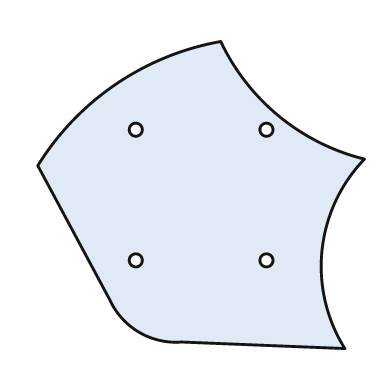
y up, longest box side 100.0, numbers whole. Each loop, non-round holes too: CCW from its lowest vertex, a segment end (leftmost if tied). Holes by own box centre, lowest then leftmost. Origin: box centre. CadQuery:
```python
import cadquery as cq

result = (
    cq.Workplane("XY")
    .moveTo(44.0, -47.0)
    .threePointArc((37.0, -17.0), (50.0, 11.0))
    .threePointArc((24.0, 24.0), (6.0, 47.0))
    .threePointArc((-26.0, 34.0), (-50.0, 9.0))
    .lineTo(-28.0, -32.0)
    .threePointArc((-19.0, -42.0), (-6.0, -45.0))
    .close()
    .moveTo(-20.0, -20.0)
    .circle(2.0)
    .moveTo(20.0, -20.0)
    .circle(2.0)
    .moveTo(-20.0, 20.0)
    .circle(2.0)
    .moveTo(20.0, 20.0)
    .circle(2.0)
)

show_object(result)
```